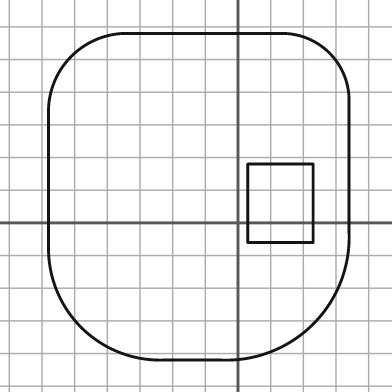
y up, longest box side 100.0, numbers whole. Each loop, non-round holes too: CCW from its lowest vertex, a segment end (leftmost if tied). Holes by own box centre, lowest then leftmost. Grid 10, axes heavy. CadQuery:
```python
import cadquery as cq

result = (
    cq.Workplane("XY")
    .moveTo(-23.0, -42.0)
    .lineTo(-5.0, -42.0)
    .threePointArc((23.0, -31.0), (34.0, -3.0))
    .lineTo(34.0, 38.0)
    .threePointArc((28.0, 52.0), (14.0, 58.0))
    .lineTo(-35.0, 58.0)
    .threePointArc((-51.0, 51.0), (-58.0, 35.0))
    .lineTo(-58.0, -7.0)
    .threePointArc((-48.0, -32.0), (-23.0, -42.0))
    .close()
    .moveTo(3.0, -6.0)
    .lineTo(23.0, -6.0)
    .lineTo(23.0, 18.0)
    .lineTo(3.0, 18.0)
    .close()
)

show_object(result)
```